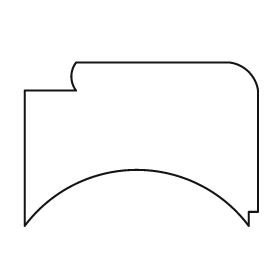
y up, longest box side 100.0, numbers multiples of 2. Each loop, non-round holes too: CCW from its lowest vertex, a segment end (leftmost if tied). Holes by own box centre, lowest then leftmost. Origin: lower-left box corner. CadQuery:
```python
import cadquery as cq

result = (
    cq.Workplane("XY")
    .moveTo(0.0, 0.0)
    .threePointArc((48.0, 24.0), (96.0, 0.0))
    .lineTo(96.0, 6.0)
    .lineTo(100.0, 6.0)
    .lineTo(100.0, 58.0)
    .threePointArc((96.0, 66.0), (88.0, 70.0))
    .lineTo(22.0, 70.0)
    .threePointArc((20.0, 64.0), (22.0, 58.0))
    .lineTo(0.0, 58.0)
    .close()
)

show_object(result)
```